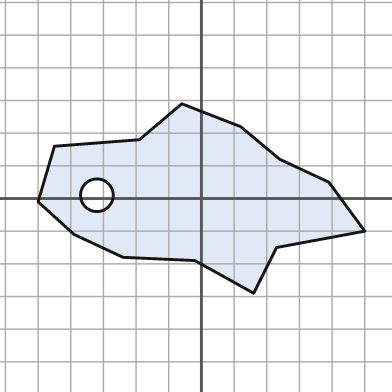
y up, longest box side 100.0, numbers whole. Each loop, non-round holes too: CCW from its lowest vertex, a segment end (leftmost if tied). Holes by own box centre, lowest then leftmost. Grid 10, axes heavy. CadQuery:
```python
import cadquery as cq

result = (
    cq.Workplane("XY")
    .moveTo(16.0, -29.0)
    .lineTo(23.0, -15.0)
    .lineTo(50.0, -10.0)
    .lineTo(39.0, 5.0)
    .lineTo(24.0, 12.0)
    .lineTo(12.0, 22.0)
    .lineTo(-6.0, 29.0)
    .lineTo(-19.0, 18.0)
    .lineTo(-45.0, 16.0)
    .lineTo(-50.0, -1.0)
    .lineTo(-39.0, -11.0)
    .lineTo(-24.0, -18.0)
    .lineTo(-2.0, -19.0)
    .close()
    .moveTo(-32.0, 1.0)
    .circle(5.0)
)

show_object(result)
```